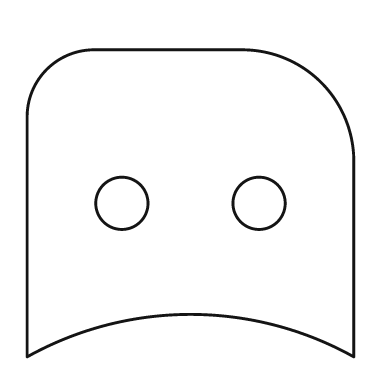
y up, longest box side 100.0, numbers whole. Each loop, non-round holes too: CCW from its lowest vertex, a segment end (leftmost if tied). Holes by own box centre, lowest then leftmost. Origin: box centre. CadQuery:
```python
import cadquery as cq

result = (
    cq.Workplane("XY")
    .moveTo(-50.0, -47.0)
    .threePointArc((0.0, -34.0), (50.0, -47.0))
    .lineTo(50.0, 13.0)
    .threePointArc((40.0, 37.0), (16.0, 47.0))
    .lineTo(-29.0, 47.0)
    .threePointArc((-44.0, 41.0), (-50.0, 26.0))
    .close()
    .moveTo(-21.0, 0.0)
    .circle(8.0)
    .moveTo(21.0, 0.0)
    .circle(8.0)
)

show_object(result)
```